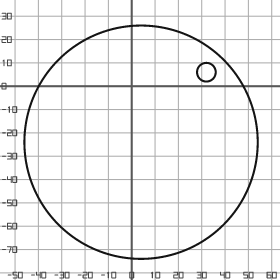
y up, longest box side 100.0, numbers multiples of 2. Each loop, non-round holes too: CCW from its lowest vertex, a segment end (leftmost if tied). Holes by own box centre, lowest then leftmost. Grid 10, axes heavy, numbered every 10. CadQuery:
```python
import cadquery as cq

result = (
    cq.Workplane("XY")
    .moveTo(4.0, -24.0)
    .circle(50.0)
    .moveTo(32.0, 6.0)
    .circle(4.0)
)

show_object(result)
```